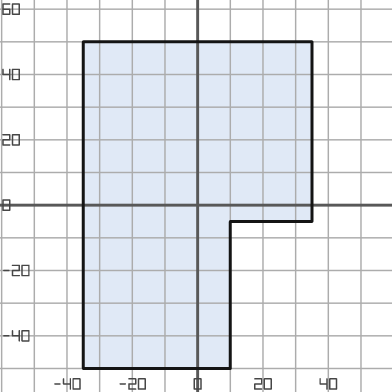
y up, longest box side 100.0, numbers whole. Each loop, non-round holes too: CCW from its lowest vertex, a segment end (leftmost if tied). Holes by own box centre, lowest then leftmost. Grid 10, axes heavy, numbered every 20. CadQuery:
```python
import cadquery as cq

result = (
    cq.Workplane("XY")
    .moveTo(-35.0, -50.0)
    .lineTo(10.0, -50.0)
    .lineTo(10.0, -5.0)
    .lineTo(35.0, -5.0)
    .lineTo(35.0, 50.0)
    .lineTo(-35.0, 50.0)
    .close()
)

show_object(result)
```